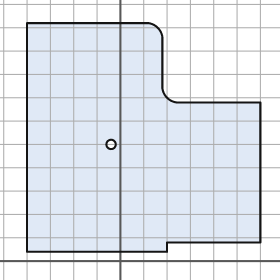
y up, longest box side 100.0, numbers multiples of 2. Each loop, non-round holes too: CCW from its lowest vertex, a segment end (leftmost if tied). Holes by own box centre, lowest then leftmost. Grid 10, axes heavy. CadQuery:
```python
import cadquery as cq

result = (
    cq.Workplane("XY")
    .moveTo(-40.0, 4.0)
    .lineTo(20.0, 4.0)
    .lineTo(20.0, 8.0)
    .lineTo(60.0, 8.0)
    .lineTo(60.0, 68.0)
    .lineTo(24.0, 68.0)
    .threePointArc((20.0, 70.0), (18.0, 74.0))
    .lineTo(18.0, 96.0)
    .threePointArc((16.0, 100.0), (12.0, 102.0))
    .lineTo(-40.0, 102.0)
    .close()
    .moveTo(-4.0, 50.0)
    .circle(2.0)
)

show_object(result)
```